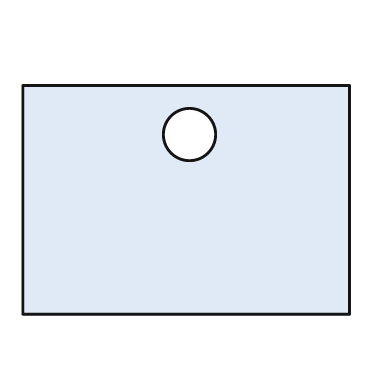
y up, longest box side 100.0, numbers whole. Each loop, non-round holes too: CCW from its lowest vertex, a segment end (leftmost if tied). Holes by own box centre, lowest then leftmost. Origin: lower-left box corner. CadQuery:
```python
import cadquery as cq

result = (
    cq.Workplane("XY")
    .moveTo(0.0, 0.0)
    .lineTo(100.0, 0.0)
    .lineTo(100.0, 70.0)
    .lineTo(0.0, 70.0)
    .close()
    .moveTo(51.0, 55.0)
    .circle(8.0)
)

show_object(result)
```